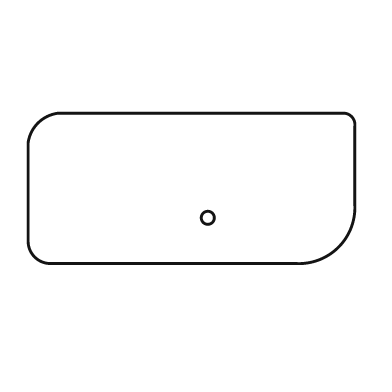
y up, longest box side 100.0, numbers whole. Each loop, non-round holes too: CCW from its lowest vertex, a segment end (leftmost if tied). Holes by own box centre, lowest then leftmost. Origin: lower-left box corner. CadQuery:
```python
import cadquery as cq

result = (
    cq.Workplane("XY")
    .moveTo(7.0, 0.0)
    .lineTo(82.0, 0.0)
    .threePointArc((95.0, 5.0), (100.0, 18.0))
    .lineTo(100.0, 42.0)
    .threePointArc((99.0, 45.0), (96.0, 46.0))
    .lineTo(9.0, 46.0)
    .threePointArc((3.0, 43.0), (0.0, 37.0))
    .lineTo(0.0, 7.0)
    .threePointArc((2.0, 2.0), (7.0, 0.0))
    .close()
    .moveTo(55.0, 14.0)
    .circle(2.0)
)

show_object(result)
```